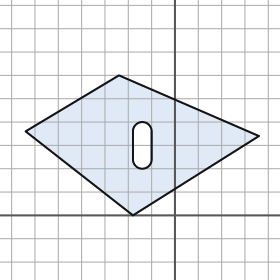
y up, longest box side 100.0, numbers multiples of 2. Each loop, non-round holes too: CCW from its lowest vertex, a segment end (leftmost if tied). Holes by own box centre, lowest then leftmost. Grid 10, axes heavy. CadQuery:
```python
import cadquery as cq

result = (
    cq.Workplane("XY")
    .moveTo(-18.0, 0.0)
    .lineTo(36.0, 34.0)
    .lineTo(-24.0, 60.0)
    .lineTo(-64.0, 36.0)
    .close()
    .moveTo(-18.0, 24.0)
    .threePointArc((-14.0, 20.0), (-10.0, 24.0))
    .lineTo(-10.0, 36.0)
    .threePointArc((-14.0, 40.0), (-18.0, 36.0))
    .close()
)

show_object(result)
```